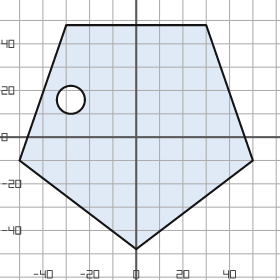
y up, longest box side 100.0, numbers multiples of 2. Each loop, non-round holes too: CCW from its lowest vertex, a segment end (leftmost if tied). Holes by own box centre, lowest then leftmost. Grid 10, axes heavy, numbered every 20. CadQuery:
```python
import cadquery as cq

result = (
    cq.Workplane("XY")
    .moveTo(0.0, -48.0)
    .lineTo(50.0, -10.0)
    .lineTo(30.0, 48.0)
    .lineTo(-30.0, 48.0)
    .lineTo(-50.0, -10.0)
    .close()
    .moveTo(-28.0, 16.0)
    .circle(6.0)
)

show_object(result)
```